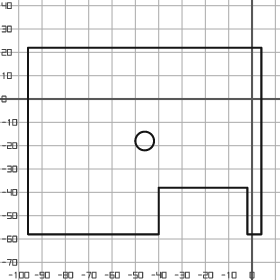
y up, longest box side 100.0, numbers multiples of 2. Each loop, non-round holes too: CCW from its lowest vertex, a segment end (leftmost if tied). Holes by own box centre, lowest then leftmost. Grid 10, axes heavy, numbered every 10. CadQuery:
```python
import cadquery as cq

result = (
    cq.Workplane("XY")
    .moveTo(-96.0, -58.0)
    .lineTo(-40.0, -58.0)
    .lineTo(-40.0, -38.0)
    .lineTo(-2.0, -38.0)
    .lineTo(-2.0, -58.0)
    .lineTo(4.0, -58.0)
    .lineTo(4.0, 22.0)
    .lineTo(-96.0, 22.0)
    .close()
    .moveTo(-46.0, -18.0)
    .circle(4.0)
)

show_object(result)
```